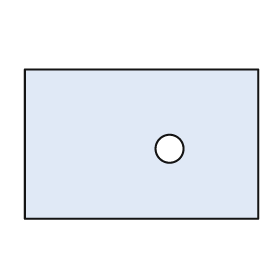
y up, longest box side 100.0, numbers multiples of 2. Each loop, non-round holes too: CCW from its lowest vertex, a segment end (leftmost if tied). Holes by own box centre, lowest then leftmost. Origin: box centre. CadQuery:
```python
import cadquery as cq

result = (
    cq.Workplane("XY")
    .moveTo(-50.0, -32.0)
    .lineTo(50.0, -32.0)
    .lineTo(50.0, 32.0)
    .lineTo(-50.0, 32.0)
    .close()
    .moveTo(12.0, -2.0)
    .circle(6.0)
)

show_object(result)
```